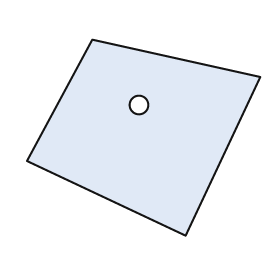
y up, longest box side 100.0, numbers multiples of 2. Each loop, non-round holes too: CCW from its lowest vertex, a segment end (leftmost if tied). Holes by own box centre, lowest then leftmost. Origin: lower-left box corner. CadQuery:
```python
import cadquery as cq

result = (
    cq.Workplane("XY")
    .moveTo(68.0, 0.0)
    .lineTo(100.0, 68.0)
    .lineTo(28.0, 84.0)
    .lineTo(0.0, 32.0)
    .close()
    .moveTo(48.0, 56.0)
    .circle(4.0)
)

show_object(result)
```